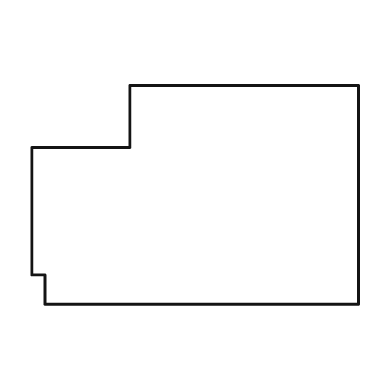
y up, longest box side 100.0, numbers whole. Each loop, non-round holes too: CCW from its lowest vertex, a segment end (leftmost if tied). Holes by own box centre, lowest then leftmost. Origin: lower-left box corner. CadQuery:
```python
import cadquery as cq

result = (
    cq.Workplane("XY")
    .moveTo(4.0, 0.0)
    .lineTo(100.0, 0.0)
    .lineTo(100.0, 67.0)
    .lineTo(30.0, 67.0)
    .lineTo(30.0, 48.0)
    .lineTo(0.0, 48.0)
    .lineTo(0.0, 9.0)
    .lineTo(4.0, 9.0)
    .close()
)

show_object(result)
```